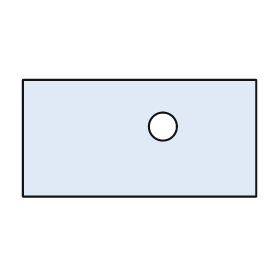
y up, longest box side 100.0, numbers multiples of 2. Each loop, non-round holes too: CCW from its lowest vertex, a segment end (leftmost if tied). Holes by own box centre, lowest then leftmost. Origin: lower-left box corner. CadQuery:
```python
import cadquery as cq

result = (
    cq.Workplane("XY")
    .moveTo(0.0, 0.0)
    .lineTo(100.0, 0.0)
    .lineTo(100.0, 50.0)
    .lineTo(0.0, 50.0)
    .close()
    .moveTo(60.0, 30.0)
    .circle(6.0)
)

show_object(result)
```